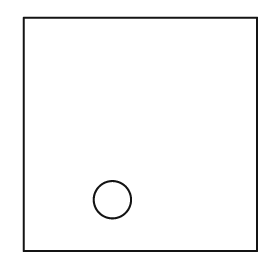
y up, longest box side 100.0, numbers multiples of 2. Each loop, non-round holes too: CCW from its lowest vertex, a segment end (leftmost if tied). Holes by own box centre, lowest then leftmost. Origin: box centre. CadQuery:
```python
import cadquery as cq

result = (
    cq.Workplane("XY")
    .moveTo(-50.0, -50.0)
    .lineTo(50.0, -50.0)
    .lineTo(50.0, 50.0)
    .lineTo(-50.0, 50.0)
    .close()
    .moveTo(-12.0, -28.0)
    .circle(8.0)
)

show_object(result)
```